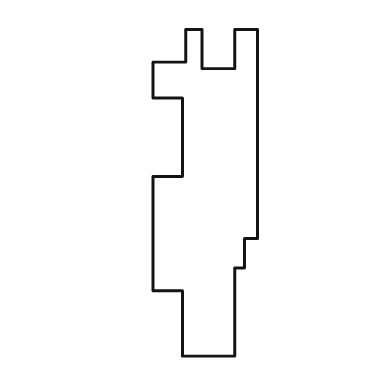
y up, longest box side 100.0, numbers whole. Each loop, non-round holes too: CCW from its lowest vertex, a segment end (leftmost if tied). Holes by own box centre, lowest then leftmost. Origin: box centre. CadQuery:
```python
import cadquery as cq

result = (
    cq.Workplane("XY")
    .moveTo(-7.0, -50.0)
    .lineTo(9.0, -50.0)
    .lineTo(9.0, -23.0)
    .lineTo(12.0, -23.0)
    .lineTo(12.0, -14.0)
    .lineTo(16.0, -14.0)
    .lineTo(16.0, 50.0)
    .lineTo(9.0, 50.0)
    .lineTo(9.0, 38.0)
    .lineTo(-1.0, 38.0)
    .lineTo(-1.0, 50.0)
    .lineTo(-6.0, 50.0)
    .lineTo(-6.0, 40.0)
    .lineTo(-16.0, 40.0)
    .lineTo(-16.0, 29.0)
    .lineTo(-7.0, 29.0)
    .lineTo(-7.0, 5.0)
    .lineTo(-16.0, 5.0)
    .lineTo(-16.0, -30.0)
    .lineTo(-7.0, -30.0)
    .close()
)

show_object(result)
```